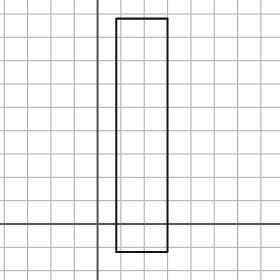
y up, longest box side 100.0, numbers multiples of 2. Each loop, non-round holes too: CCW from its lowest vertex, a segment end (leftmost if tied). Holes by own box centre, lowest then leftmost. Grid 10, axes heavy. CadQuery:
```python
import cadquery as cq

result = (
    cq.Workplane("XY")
    .moveTo(8.0, -12.0)
    .lineTo(30.0, -12.0)
    .lineTo(30.0, 88.0)
    .lineTo(8.0, 88.0)
    .close()
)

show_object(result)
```